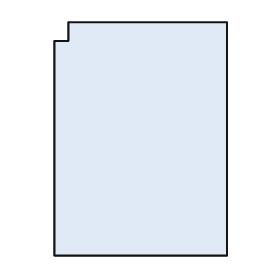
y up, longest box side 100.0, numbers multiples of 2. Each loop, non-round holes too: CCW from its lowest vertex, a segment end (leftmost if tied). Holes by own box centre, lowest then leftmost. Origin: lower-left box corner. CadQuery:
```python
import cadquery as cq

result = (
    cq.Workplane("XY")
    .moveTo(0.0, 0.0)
    .lineTo(74.0, 0.0)
    .lineTo(74.0, 100.0)
    .lineTo(6.0, 100.0)
    .lineTo(6.0, 92.0)
    .lineTo(0.0, 92.0)
    .close()
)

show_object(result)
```